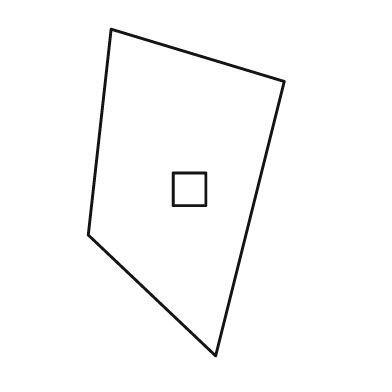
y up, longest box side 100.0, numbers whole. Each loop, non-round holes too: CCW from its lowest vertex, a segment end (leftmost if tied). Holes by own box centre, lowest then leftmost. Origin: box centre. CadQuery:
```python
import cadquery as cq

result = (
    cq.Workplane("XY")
    .moveTo(9.0, -50.0)
    .lineTo(30.0, 34.0)
    .lineTo(-23.0, 50.0)
    .lineTo(-30.0, -13.0)
    .close()
    .moveTo(-4.0, -4.0)
    .lineTo(6.0, -4.0)
    .lineTo(6.0, 6.0)
    .lineTo(-4.0, 6.0)
    .close()
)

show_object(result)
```